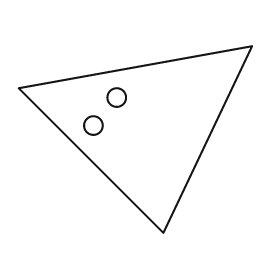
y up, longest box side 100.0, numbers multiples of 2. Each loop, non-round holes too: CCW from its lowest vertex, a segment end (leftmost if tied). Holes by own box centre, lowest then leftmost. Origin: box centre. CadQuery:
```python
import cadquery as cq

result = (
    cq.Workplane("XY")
    .moveTo(12.0, -40.0)
    .lineTo(50.0, 40.0)
    .lineTo(-50.0, 22.0)
    .close()
    .moveTo(-18.0, 6.0)
    .circle(4.0)
    .moveTo(-8.0, 18.0)
    .circle(4.0)
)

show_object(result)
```